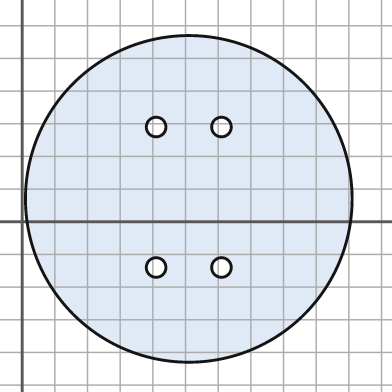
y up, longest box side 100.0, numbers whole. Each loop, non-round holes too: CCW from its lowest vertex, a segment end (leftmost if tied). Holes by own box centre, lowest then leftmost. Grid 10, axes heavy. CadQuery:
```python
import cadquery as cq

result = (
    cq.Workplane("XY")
    .moveTo(51.0, 7.0)
    .circle(50.0)
    .moveTo(41.0, -14.0)
    .circle(3.0)
    .moveTo(61.0, -14.0)
    .circle(3.0)
    .moveTo(41.0, 29.0)
    .circle(3.0)
    .moveTo(61.0, 29.0)
    .circle(3.0)
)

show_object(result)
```